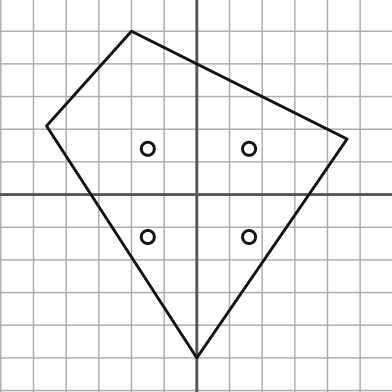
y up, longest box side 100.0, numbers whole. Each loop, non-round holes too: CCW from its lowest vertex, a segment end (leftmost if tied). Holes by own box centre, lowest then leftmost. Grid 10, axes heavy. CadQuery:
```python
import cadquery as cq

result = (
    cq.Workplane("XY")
    .moveTo(0.0, -50.0)
    .lineTo(46.0, 17.0)
    .lineTo(-20.0, 50.0)
    .lineTo(-46.0, 21.0)
    .close()
    .moveTo(-15.0, -13.0)
    .circle(2.0)
    .moveTo(16.0, -13.0)
    .circle(2.0)
    .moveTo(-15.0, 14.0)
    .circle(2.0)
    .moveTo(16.0, 14.0)
    .circle(2.0)
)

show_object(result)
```